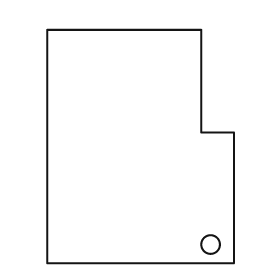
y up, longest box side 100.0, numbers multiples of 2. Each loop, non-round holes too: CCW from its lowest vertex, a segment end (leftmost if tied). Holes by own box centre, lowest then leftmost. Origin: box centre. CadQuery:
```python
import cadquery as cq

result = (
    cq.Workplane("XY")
    .moveTo(-40.0, -50.0)
    .lineTo(40.0, -50.0)
    .lineTo(40.0, 6.0)
    .lineTo(26.0, 6.0)
    .lineTo(26.0, 50.0)
    .lineTo(-40.0, 50.0)
    .close()
    .moveTo(30.0, -42.0)
    .circle(4.0)
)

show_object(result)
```